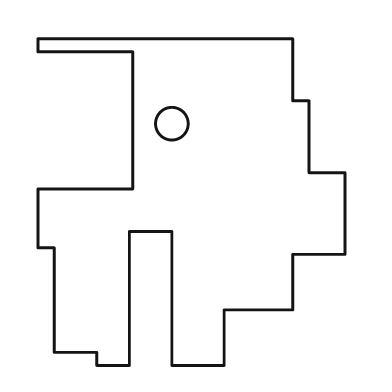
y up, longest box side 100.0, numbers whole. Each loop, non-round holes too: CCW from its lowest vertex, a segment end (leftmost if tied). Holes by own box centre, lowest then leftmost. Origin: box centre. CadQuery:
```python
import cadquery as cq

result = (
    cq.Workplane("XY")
    .moveTo(-29.0, -50.0)
    .lineTo(-19.0, -50.0)
    .lineTo(-19.0, -9.0)
    .lineTo(-6.0, -9.0)
    .lineTo(-6.0, -50.0)
    .lineTo(10.0, -50.0)
    .lineTo(10.0, -33.0)
    .lineTo(31.0, -33.0)
    .lineTo(31.0, -16.0)
    .lineTo(47.0, -16.0)
    .lineTo(47.0, 9.0)
    .lineTo(36.0, 9.0)
    .lineTo(36.0, 31.0)
    .lineTo(31.0, 31.0)
    .lineTo(31.0, 50.0)
    .lineTo(-47.0, 50.0)
    .lineTo(-47.0, 46.0)
    .lineTo(-18.0, 46.0)
    .lineTo(-18.0, 4.0)
    .lineTo(-47.0, 4.0)
    .lineTo(-47.0, -14.0)
    .lineTo(-42.0, -14.0)
    .lineTo(-42.0, -46.0)
    .lineTo(-29.0, -46.0)
    .close()
    .moveTo(-6.0, 24.0)
    .circle(5.0)
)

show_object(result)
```